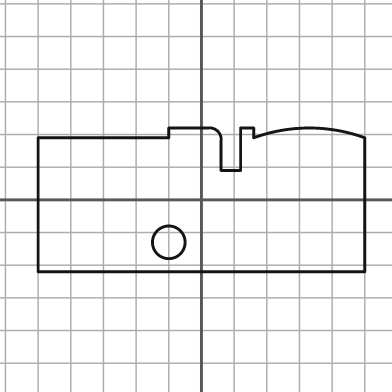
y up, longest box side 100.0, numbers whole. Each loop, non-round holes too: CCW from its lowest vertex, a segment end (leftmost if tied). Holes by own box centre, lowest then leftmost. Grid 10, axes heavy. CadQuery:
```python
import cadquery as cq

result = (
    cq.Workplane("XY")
    .moveTo(-50.0, -22.0)
    .lineTo(50.0, -22.0)
    .lineTo(50.0, 19.0)
    .threePointArc((33.0, 22.0), (16.0, 19.0))
    .lineTo(16.0, 22.0)
    .lineTo(12.0, 22.0)
    .lineTo(12.0, 9.0)
    .lineTo(6.0, 9.0)
    .lineTo(6.0, 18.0)
    .threePointArc((5.0, 21.0), (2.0, 22.0))
    .lineTo(-10.0, 22.0)
    .lineTo(-10.0, 19.0)
    .lineTo(-50.0, 19.0)
    .close()
    .moveTo(-10.0, -13.0)
    .circle(5.0)
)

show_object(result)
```